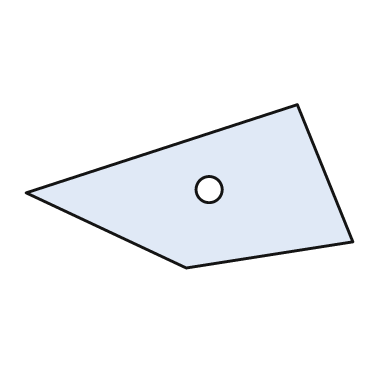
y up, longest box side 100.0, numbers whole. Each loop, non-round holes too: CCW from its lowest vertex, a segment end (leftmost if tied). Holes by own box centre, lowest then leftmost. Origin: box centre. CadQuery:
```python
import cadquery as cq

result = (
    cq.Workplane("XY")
    .moveTo(-1.0, -25.0)
    .lineTo(50.0, -17.0)
    .lineTo(33.0, 25.0)
    .lineTo(-50.0, -2.0)
    .close()
    .moveTo(6.0, -1.0)
    .circle(4.0)
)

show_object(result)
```